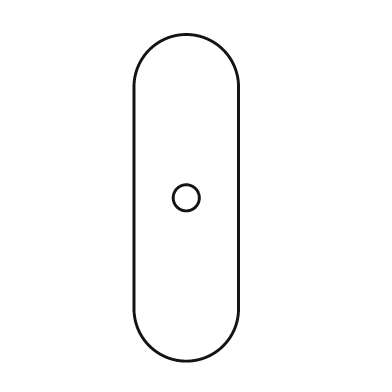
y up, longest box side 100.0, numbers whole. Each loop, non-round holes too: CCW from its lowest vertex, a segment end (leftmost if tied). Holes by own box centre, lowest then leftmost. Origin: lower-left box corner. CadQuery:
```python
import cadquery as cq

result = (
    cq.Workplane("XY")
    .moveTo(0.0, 16.0)
    .threePointArc((16.0, 0.0), (32.0, 16.0))
    .lineTo(32.0, 84.0)
    .threePointArc((16.0, 100.0), (0.0, 84.0))
    .close()
    .moveTo(16.0, 50.0)
    .circle(4.0)
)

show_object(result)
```